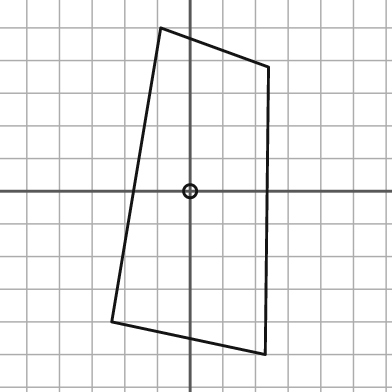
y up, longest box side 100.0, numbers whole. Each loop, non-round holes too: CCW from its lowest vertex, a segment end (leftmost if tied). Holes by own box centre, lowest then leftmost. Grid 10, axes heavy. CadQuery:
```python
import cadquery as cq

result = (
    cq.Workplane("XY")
    .moveTo(23.0, -50.0)
    .lineTo(24.0, 38.0)
    .lineTo(-9.0, 50.0)
    .lineTo(-24.0, -40.0)
    .close()
    .moveTo(0.0, 0.0)
    .circle(2.0)
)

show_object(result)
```